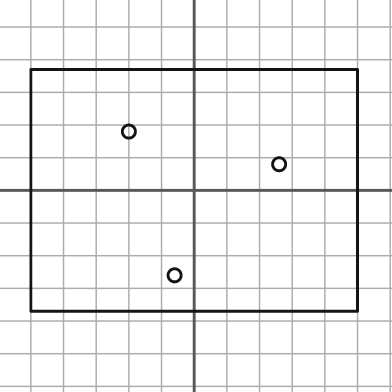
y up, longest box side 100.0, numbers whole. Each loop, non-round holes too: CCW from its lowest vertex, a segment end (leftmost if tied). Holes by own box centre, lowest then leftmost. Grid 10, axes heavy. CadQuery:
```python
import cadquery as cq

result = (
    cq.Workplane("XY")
    .moveTo(-50.0, -37.0)
    .lineTo(50.0, -37.0)
    .lineTo(50.0, 37.0)
    .lineTo(-50.0, 37.0)
    .close()
    .moveTo(-6.0, -26.0)
    .circle(2.0)
    .moveTo(26.0, 8.0)
    .circle(2.0)
    .moveTo(-20.0, 18.0)
    .circle(2.0)
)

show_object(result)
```